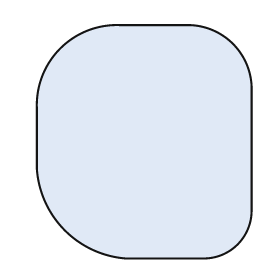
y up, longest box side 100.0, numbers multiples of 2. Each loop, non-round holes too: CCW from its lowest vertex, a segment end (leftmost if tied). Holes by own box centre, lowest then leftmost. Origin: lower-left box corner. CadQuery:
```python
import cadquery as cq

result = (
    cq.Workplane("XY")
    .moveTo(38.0, 0.0)
    .lineTo(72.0, 0.0)
    .threePointArc((86.0, 6.0), (92.0, 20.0))
    .lineTo(92.0, 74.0)
    .threePointArc((84.0, 92.0), (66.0, 100.0))
    .lineTo(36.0, 100.0)
    .threePointArc((10.0, 90.0), (0.0, 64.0))
    .lineTo(0.0, 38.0)
    .threePointArc((12.0, 12.0), (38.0, 0.0))
    .close()
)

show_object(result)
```